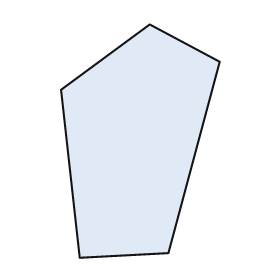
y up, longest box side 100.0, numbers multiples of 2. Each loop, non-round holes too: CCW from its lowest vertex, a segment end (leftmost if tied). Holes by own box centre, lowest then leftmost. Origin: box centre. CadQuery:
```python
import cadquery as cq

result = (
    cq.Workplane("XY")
    .moveTo(-26.0, -50.0)
    .lineTo(12.0, -48.0)
    .lineTo(34.0, 34.0)
    .lineTo(4.0, 50.0)
    .lineTo(-34.0, 22.0)
    .close()
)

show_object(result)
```